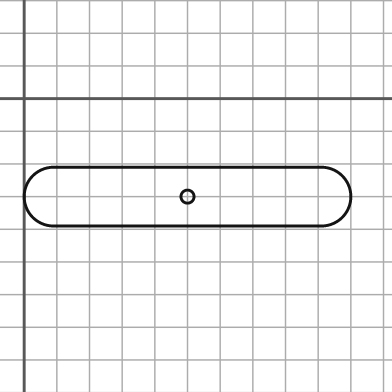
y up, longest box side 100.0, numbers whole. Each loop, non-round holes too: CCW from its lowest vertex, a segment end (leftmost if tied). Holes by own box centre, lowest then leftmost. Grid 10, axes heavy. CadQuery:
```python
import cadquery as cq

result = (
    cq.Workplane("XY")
    .moveTo(9.0, -39.0)
    .lineTo(91.0, -39.0)
    .threePointArc((100.0, -30.0), (91.0, -21.0))
    .lineTo(9.0, -21.0)
    .threePointArc((0.0, -30.0), (9.0, -39.0))
    .close()
    .moveTo(50.0, -30.0)
    .circle(2.0)
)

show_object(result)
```